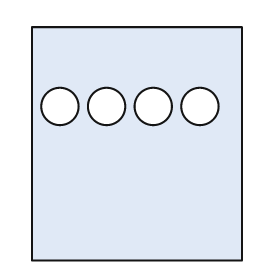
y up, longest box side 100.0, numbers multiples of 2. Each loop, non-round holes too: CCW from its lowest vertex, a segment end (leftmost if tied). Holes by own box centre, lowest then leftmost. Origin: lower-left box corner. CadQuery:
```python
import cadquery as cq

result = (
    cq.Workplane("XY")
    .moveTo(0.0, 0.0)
    .lineTo(90.0, 0.0)
    .lineTo(90.0, 100.0)
    .lineTo(0.0, 100.0)
    .close()
    .moveTo(12.0, 66.0)
    .circle(8.0)
    .moveTo(32.0, 66.0)
    .circle(8.0)
    .moveTo(52.0, 66.0)
    .circle(8.0)
    .moveTo(72.0, 66.0)
    .circle(8.0)
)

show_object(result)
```